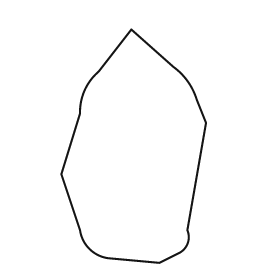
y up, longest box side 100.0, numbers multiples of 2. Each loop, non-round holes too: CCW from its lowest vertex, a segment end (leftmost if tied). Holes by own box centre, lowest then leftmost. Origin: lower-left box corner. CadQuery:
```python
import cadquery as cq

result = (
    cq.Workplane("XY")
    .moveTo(42.0, 0.0)
    .lineTo(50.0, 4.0)
    .threePointArc((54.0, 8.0), (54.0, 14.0))
    .lineTo(62.0, 60.0)
    .lineTo(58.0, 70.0)
    .threePointArc((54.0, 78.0), (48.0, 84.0))
    .lineTo(30.0, 100.0)
    .lineTo(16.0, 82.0)
    .threePointArc((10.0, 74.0), (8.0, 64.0))
    .lineTo(0.0, 38.0)
    .lineTo(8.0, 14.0)
    .threePointArc((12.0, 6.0), (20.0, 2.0))
    .close()
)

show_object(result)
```